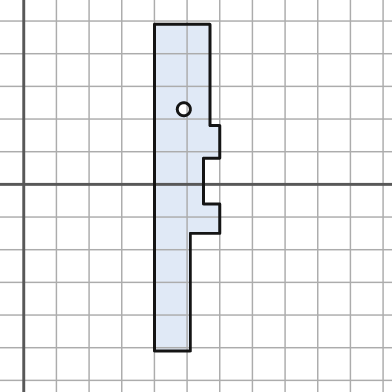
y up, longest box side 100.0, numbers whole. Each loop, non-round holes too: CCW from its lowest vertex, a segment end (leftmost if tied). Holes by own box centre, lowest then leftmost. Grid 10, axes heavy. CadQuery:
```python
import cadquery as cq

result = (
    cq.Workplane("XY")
    .moveTo(40.0, -51.0)
    .lineTo(51.0, -51.0)
    .lineTo(51.0, -15.0)
    .lineTo(60.0, -15.0)
    .lineTo(60.0, -6.0)
    .lineTo(55.0, -6.0)
    .lineTo(55.0, 8.0)
    .lineTo(60.0, 8.0)
    .lineTo(60.0, 18.0)
    .lineTo(57.0, 18.0)
    .lineTo(57.0, 49.0)
    .lineTo(40.0, 49.0)
    .close()
    .moveTo(49.0, 23.0)
    .circle(2.0)
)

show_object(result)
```